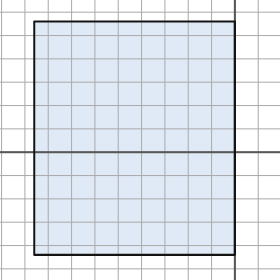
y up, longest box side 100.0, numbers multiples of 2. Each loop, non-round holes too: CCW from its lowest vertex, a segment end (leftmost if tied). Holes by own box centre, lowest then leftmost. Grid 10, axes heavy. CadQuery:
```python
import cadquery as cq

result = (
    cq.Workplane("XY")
    .moveTo(-86.0, -44.0)
    .lineTo(0.0, -44.0)
    .lineTo(0.0, 56.0)
    .lineTo(-86.0, 56.0)
    .close()
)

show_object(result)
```